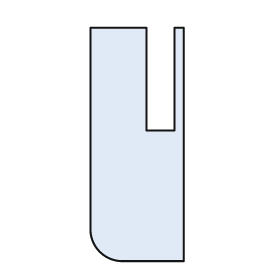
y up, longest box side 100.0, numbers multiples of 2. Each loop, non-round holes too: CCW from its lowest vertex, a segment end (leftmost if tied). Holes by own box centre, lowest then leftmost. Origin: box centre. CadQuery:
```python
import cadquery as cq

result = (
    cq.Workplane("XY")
    .moveTo(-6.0, -50.0)
    .lineTo(20.0, -50.0)
    .lineTo(20.0, 50.0)
    .lineTo(16.0, 50.0)
    .lineTo(16.0, 6.0)
    .lineTo(4.0, 6.0)
    .lineTo(4.0, 50.0)
    .lineTo(-20.0, 50.0)
    .lineTo(-20.0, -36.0)
    .threePointArc((-16.0, -46.0), (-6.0, -50.0))
    .close()
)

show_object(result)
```